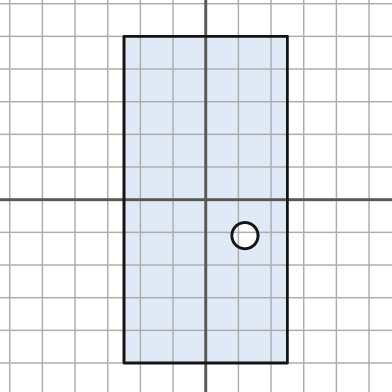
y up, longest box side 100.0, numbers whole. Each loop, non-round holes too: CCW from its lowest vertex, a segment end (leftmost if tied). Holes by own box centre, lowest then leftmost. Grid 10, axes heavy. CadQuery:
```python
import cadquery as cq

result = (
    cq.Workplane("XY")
    .moveTo(-25.0, -50.0)
    .lineTo(25.0, -50.0)
    .lineTo(25.0, 50.0)
    .lineTo(-25.0, 50.0)
    .close()
    .moveTo(12.0, -11.0)
    .circle(4.0)
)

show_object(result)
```